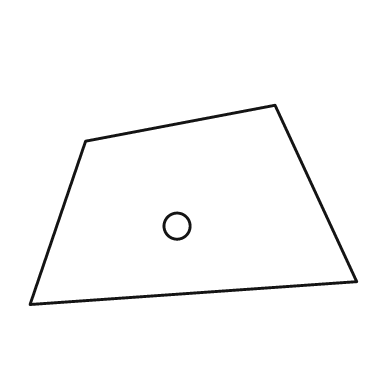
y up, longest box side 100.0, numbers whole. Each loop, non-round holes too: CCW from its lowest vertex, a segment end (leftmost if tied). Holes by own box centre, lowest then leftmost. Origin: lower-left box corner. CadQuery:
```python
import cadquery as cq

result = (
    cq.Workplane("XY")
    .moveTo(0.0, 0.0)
    .lineTo(100.0, 7.0)
    .lineTo(75.0, 61.0)
    .lineTo(17.0, 50.0)
    .close()
    .moveTo(45.0, 24.0)
    .circle(4.0)
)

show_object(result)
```